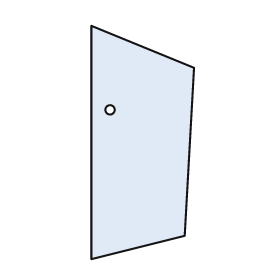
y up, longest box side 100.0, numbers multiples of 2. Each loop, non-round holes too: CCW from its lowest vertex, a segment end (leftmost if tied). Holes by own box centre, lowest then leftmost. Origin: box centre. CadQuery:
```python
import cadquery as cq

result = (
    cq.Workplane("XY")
    .moveTo(-22.0, -50.0)
    .lineTo(18.0, -40.0)
    .lineTo(22.0, 32.0)
    .lineTo(-22.0, 50.0)
    .close()
    .moveTo(-14.0, 14.0)
    .circle(2.0)
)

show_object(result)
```